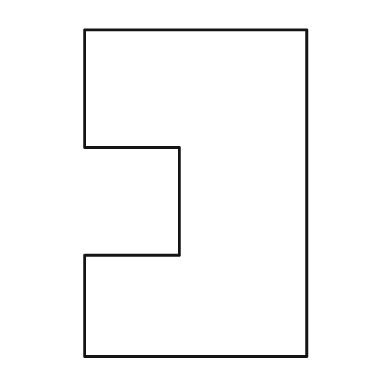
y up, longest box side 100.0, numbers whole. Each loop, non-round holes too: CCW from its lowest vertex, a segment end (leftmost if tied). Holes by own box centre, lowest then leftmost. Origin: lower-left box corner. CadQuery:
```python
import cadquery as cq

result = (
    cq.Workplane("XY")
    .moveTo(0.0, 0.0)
    .lineTo(68.0, 0.0)
    .lineTo(68.0, 100.0)
    .lineTo(0.0, 100.0)
    .lineTo(0.0, 64.0)
    .lineTo(29.0, 64.0)
    .lineTo(29.0, 31.0)
    .lineTo(0.0, 31.0)
    .close()
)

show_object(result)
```